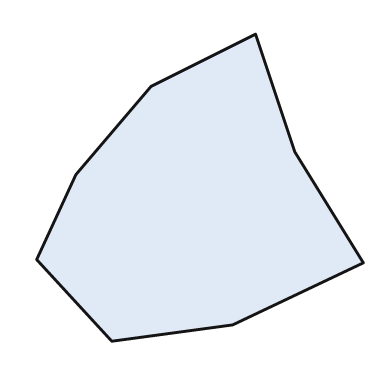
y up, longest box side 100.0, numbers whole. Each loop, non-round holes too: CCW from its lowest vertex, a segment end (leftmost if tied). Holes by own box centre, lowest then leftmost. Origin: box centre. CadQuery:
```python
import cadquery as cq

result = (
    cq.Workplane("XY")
    .moveTo(-27.0, -47.0)
    .lineTo(10.0, -42.0)
    .lineTo(50.0, -23.0)
    .lineTo(29.0, 11.0)
    .lineTo(17.0, 47.0)
    .lineTo(-15.0, 31.0)
    .lineTo(-38.0, 4.0)
    .lineTo(-50.0, -22.0)
    .close()
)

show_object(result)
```